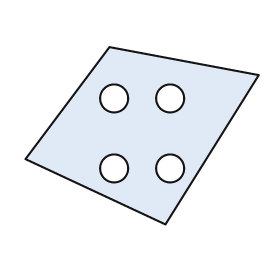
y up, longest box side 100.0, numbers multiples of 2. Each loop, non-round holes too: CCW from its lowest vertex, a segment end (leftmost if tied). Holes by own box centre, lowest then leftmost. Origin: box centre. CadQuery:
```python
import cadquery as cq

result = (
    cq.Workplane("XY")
    .moveTo(10.0, -38.0)
    .lineTo(50.0, 26.0)
    .lineTo(-14.0, 38.0)
    .lineTo(-50.0, -10.0)
    .close()
    .moveTo(-12.0, -14.0)
    .circle(6.0)
    .moveTo(12.0, -14.0)
    .circle(6.0)
    .moveTo(-12.0, 16.0)
    .circle(6.0)
    .moveTo(12.0, 16.0)
    .circle(6.0)
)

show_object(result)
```